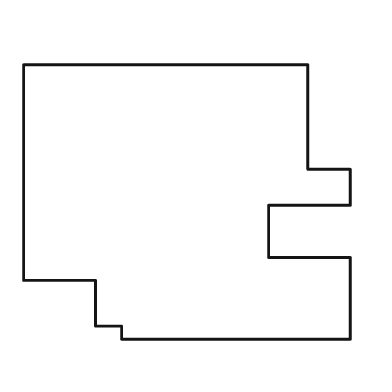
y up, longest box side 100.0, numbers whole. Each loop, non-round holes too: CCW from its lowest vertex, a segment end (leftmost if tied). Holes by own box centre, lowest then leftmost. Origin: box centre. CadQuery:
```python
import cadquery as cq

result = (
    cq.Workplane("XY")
    .moveTo(-20.0, -42.0)
    .lineTo(50.0, -42.0)
    .lineTo(50.0, -17.0)
    .lineTo(25.0, -17.0)
    .lineTo(25.0, -1.0)
    .lineTo(50.0, -1.0)
    .lineTo(50.0, 10.0)
    .lineTo(37.0, 10.0)
    .lineTo(37.0, 42.0)
    .lineTo(-50.0, 42.0)
    .lineTo(-50.0, -24.0)
    .lineTo(-28.0, -24.0)
    .lineTo(-28.0, -38.0)
    .lineTo(-20.0, -38.0)
    .close()
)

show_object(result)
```